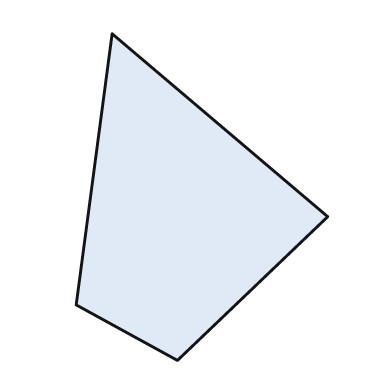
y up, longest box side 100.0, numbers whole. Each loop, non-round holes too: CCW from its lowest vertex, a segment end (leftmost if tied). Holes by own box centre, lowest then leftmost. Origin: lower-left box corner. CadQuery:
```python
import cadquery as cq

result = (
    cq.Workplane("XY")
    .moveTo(31.0, 0.0)
    .lineTo(77.0, 44.0)
    .lineTo(11.0, 100.0)
    .lineTo(0.0, 17.0)
    .close()
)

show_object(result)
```